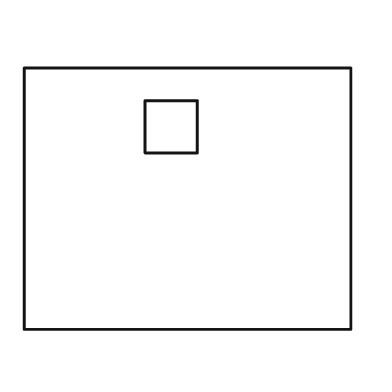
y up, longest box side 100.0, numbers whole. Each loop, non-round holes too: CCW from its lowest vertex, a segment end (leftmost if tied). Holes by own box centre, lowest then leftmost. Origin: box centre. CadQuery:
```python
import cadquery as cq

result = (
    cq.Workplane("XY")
    .moveTo(-50.0, -40.0)
    .lineTo(50.0, -40.0)
    .lineTo(50.0, 40.0)
    .lineTo(-50.0, 40.0)
    .close()
    .moveTo(-13.0, 14.0)
    .lineTo(3.0, 14.0)
    .lineTo(3.0, 30.0)
    .lineTo(-13.0, 30.0)
    .close()
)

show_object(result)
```